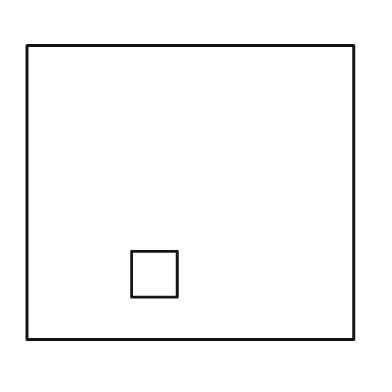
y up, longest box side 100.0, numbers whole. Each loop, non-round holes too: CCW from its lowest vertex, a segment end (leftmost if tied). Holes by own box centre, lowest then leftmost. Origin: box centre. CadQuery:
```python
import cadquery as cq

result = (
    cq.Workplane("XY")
    .moveTo(-50.0, -45.0)
    .lineTo(50.0, -45.0)
    .lineTo(50.0, 45.0)
    .lineTo(-50.0, 45.0)
    .close()
    .moveTo(-18.0, -32.0)
    .lineTo(-4.0, -32.0)
    .lineTo(-4.0, -18.0)
    .lineTo(-18.0, -18.0)
    .close()
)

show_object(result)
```